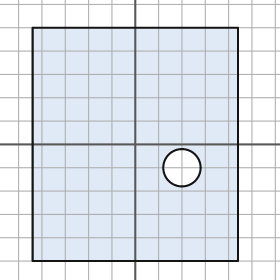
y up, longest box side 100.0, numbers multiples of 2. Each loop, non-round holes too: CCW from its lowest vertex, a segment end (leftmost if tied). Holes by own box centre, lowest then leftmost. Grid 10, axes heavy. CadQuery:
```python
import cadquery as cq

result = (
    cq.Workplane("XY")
    .moveTo(-44.0, -50.0)
    .lineTo(44.0, -50.0)
    .lineTo(44.0, 50.0)
    .lineTo(-44.0, 50.0)
    .close()
    .moveTo(20.0, -10.0)
    .circle(8.0)
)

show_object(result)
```